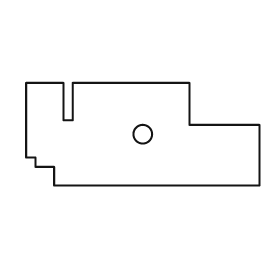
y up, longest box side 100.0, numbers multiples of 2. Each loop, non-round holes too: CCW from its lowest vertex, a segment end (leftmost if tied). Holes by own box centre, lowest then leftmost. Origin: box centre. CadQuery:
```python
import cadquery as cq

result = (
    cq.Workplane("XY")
    .moveTo(-38.0, -22.0)
    .lineTo(50.0, -22.0)
    .lineTo(50.0, 4.0)
    .lineTo(20.0, 4.0)
    .lineTo(20.0, 22.0)
    .lineTo(-30.0, 22.0)
    .lineTo(-30.0, 6.0)
    .lineTo(-34.0, 6.0)
    .lineTo(-34.0, 22.0)
    .lineTo(-50.0, 22.0)
    .lineTo(-50.0, -10.0)
    .lineTo(-46.0, -10.0)
    .lineTo(-46.0, -14.0)
    .lineTo(-38.0, -14.0)
    .close()
    .moveTo(0.0, 0.0)
    .circle(4.0)
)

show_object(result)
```